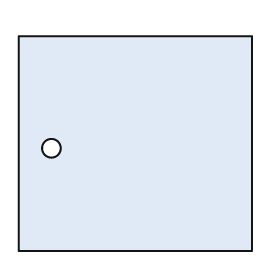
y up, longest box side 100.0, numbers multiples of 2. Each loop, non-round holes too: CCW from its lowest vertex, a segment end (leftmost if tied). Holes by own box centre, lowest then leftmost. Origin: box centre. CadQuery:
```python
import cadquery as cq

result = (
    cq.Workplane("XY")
    .moveTo(-50.0, -46.0)
    .lineTo(50.0, -46.0)
    .lineTo(50.0, 46.0)
    .lineTo(-50.0, 46.0)
    .close()
    .moveTo(-36.0, -2.0)
    .circle(4.0)
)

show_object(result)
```